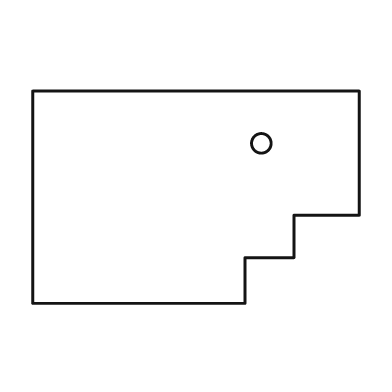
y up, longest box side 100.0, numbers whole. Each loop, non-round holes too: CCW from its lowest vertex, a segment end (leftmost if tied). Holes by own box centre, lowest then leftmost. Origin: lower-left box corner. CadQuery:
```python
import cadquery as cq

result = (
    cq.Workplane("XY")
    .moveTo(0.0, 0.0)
    .lineTo(65.0, 0.0)
    .lineTo(65.0, 14.0)
    .lineTo(80.0, 14.0)
    .lineTo(80.0, 27.0)
    .lineTo(100.0, 27.0)
    .lineTo(100.0, 65.0)
    .lineTo(0.0, 65.0)
    .close()
    .moveTo(70.0, 49.0)
    .circle(3.0)
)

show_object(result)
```